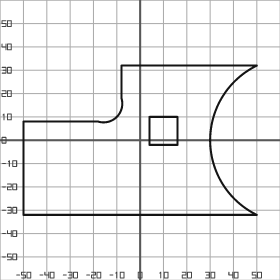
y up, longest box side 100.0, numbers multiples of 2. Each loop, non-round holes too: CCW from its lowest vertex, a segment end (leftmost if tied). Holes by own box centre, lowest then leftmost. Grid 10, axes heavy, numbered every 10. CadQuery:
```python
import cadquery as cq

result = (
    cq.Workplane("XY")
    .moveTo(-50.0, -32.0)
    .lineTo(50.0, -32.0)
    .threePointArc((30.0, 0.0), (50.0, 32.0))
    .lineTo(-8.0, 32.0)
    .lineTo(-8.0, 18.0)
    .threePointArc((-10.0, 10.0), (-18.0, 8.0))
    .lineTo(-50.0, 8.0)
    .close()
    .moveTo(4.0, -2.0)
    .lineTo(16.0, -2.0)
    .lineTo(16.0, 10.0)
    .lineTo(4.0, 10.0)
    .close()
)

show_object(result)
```